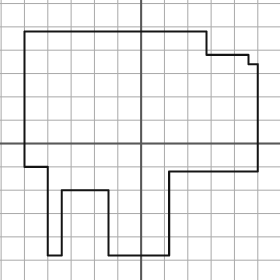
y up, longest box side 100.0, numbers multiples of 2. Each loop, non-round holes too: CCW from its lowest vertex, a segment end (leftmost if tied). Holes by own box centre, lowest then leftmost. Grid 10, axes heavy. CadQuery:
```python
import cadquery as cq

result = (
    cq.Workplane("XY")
    .moveTo(-40.0, -48.0)
    .lineTo(-34.0, -48.0)
    .lineTo(-34.0, -20.0)
    .lineTo(-14.0, -20.0)
    .lineTo(-14.0, -48.0)
    .lineTo(12.0, -48.0)
    .lineTo(12.0, -12.0)
    .lineTo(50.0, -12.0)
    .lineTo(50.0, 34.0)
    .lineTo(46.0, 34.0)
    .lineTo(46.0, 38.0)
    .lineTo(28.0, 38.0)
    .lineTo(28.0, 48.0)
    .lineTo(-50.0, 48.0)
    .lineTo(-50.0, -10.0)
    .lineTo(-40.0, -10.0)
    .close()
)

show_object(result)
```